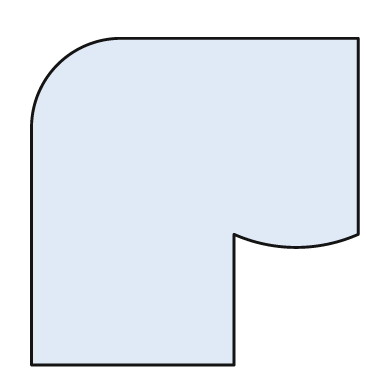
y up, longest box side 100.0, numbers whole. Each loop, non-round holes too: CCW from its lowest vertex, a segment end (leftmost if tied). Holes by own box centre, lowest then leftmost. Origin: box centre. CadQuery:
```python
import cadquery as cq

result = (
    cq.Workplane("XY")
    .moveTo(-50.0, -50.0)
    .lineTo(12.0, -50.0)
    .lineTo(12.0, -10.0)
    .threePointArc((31.0, -14.0), (50.0, -10.0))
    .lineTo(50.0, 50.0)
    .lineTo(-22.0, 50.0)
    .threePointArc((-42.0, 42.0), (-50.0, 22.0))
    .close()
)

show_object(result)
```